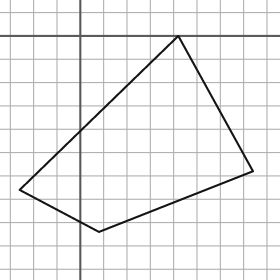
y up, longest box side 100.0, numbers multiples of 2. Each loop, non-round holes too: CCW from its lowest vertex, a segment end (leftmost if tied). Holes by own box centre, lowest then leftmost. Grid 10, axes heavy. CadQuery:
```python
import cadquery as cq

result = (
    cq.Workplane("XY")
    .moveTo(8.0, -84.0)
    .lineTo(74.0, -58.0)
    .lineTo(42.0, 0.0)
    .lineTo(-26.0, -66.0)
    .close()
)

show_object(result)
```